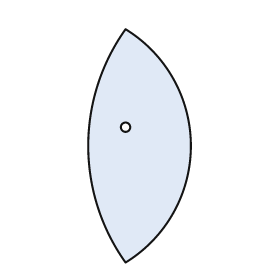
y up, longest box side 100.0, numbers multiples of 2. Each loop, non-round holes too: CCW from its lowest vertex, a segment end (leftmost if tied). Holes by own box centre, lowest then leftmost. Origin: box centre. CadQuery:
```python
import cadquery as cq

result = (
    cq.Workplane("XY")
    .moveTo(-6.0, -50.0)
    .threePointArc((22.0, 0.0), (-6.0, 50.0))
    .threePointArc((-22.0, 0.0), (-6.0, -50.0))
    .close()
    .moveTo(-6.0, 8.0)
    .circle(2.0)
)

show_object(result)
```